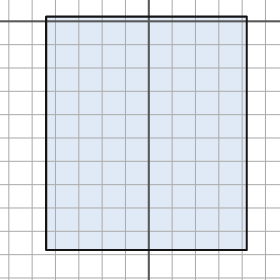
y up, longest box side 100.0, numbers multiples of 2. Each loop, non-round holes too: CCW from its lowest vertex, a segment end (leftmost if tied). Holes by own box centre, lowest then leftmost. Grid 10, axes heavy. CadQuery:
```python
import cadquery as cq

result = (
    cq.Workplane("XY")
    .moveTo(-44.0, -98.0)
    .lineTo(42.0, -98.0)
    .lineTo(42.0, 2.0)
    .lineTo(-44.0, 2.0)
    .close()
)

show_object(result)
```